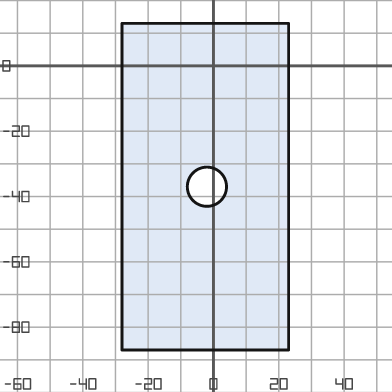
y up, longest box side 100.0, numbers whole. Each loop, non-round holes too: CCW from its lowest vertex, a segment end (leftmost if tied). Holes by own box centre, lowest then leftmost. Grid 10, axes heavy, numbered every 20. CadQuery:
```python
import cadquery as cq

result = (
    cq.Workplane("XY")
    .moveTo(-28.0, -87.0)
    .lineTo(23.0, -87.0)
    .lineTo(23.0, 13.0)
    .lineTo(-28.0, 13.0)
    .close()
    .moveTo(-2.0, -37.0)
    .circle(6.0)
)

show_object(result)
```